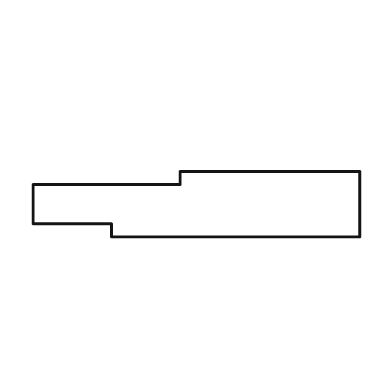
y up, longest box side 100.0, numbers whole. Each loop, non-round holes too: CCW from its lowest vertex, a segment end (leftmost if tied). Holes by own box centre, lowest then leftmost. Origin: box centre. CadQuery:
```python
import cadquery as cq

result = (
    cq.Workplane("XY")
    .moveTo(-26.0, -10.0)
    .lineTo(50.0, -10.0)
    .lineTo(50.0, 10.0)
    .lineTo(-5.0, 10.0)
    .lineTo(-5.0, 6.0)
    .lineTo(-50.0, 6.0)
    .lineTo(-50.0, -6.0)
    .lineTo(-26.0, -6.0)
    .close()
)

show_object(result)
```